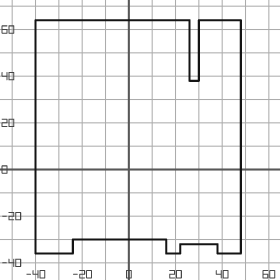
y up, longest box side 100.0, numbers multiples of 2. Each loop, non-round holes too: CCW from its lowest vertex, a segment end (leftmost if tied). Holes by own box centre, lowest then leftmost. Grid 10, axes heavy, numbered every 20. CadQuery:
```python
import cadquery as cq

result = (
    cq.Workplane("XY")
    .moveTo(-40.0, -36.0)
    .lineTo(-24.0, -36.0)
    .lineTo(-24.0, -30.0)
    .lineTo(16.0, -30.0)
    .lineTo(16.0, -36.0)
    .lineTo(22.0, -36.0)
    .lineTo(22.0, -32.0)
    .lineTo(38.0, -32.0)
    .lineTo(38.0, -36.0)
    .lineTo(48.0, -36.0)
    .lineTo(48.0, 64.0)
    .lineTo(30.0, 64.0)
    .lineTo(30.0, 38.0)
    .lineTo(26.0, 38.0)
    .lineTo(26.0, 64.0)
    .lineTo(-40.0, 64.0)
    .close()
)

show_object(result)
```